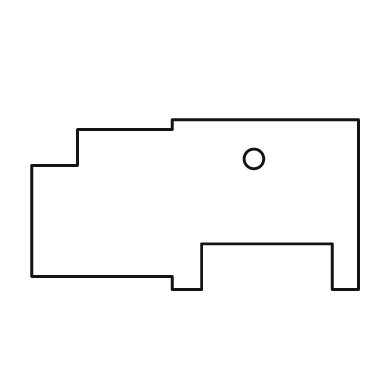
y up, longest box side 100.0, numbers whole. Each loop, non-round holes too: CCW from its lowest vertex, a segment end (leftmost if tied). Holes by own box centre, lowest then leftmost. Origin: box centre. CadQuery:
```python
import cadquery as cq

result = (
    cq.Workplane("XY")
    .moveTo(-7.0, -26.0)
    .lineTo(2.0, -26.0)
    .lineTo(2.0, -12.0)
    .lineTo(42.0, -12.0)
    .lineTo(42.0, -26.0)
    .lineTo(50.0, -26.0)
    .lineTo(50.0, 26.0)
    .lineTo(-7.0, 26.0)
    .lineTo(-7.0, 23.0)
    .lineTo(-36.0, 23.0)
    .lineTo(-36.0, 12.0)
    .lineTo(-50.0, 12.0)
    .lineTo(-50.0, -22.0)
    .lineTo(-7.0, -22.0)
    .close()
    .moveTo(18.0, 14.0)
    .circle(3.0)
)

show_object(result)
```